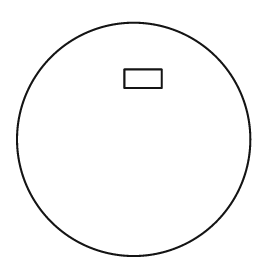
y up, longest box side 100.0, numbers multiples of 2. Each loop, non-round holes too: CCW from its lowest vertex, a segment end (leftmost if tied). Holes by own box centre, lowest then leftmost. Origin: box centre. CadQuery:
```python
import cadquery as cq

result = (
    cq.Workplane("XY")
    .moveTo(0.0, 0.0)
    .circle(50.0)
    .moveTo(-4.0, 22.0)
    .lineTo(12.0, 22.0)
    .lineTo(12.0, 30.0)
    .lineTo(-4.0, 30.0)
    .close()
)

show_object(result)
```